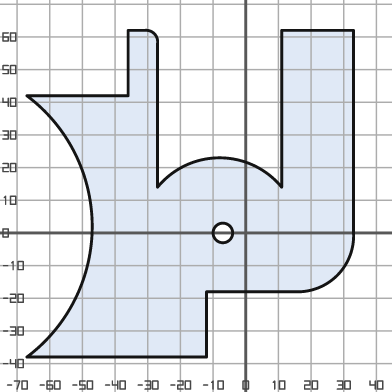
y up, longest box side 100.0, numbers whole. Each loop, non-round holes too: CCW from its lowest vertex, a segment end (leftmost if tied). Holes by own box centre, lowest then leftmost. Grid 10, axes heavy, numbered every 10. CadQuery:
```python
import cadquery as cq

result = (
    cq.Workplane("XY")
    .moveTo(-67.0, -38.0)
    .lineTo(-12.0, -38.0)
    .lineTo(-12.0, -18.0)
    .lineTo(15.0, -18.0)
    .threePointArc((28.0, -13.0), (33.0, 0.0))
    .lineTo(33.0, 62.0)
    .lineTo(11.0, 62.0)
    .lineTo(11.0, 14.0)
    .threePointArc((-8.0, 23.0), (-27.0, 14.0))
    .lineTo(-27.0, 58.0)
    .threePointArc((-28.0, 61.0), (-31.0, 62.0))
    .lineTo(-36.0, 62.0)
    .lineTo(-36.0, 42.0)
    .lineTo(-67.0, 42.0)
    .threePointArc((-47.0, 2.0), (-67.0, -38.0))
    .close()
    .moveTo(-7.0, 0.0)
    .circle(3.0)
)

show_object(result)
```